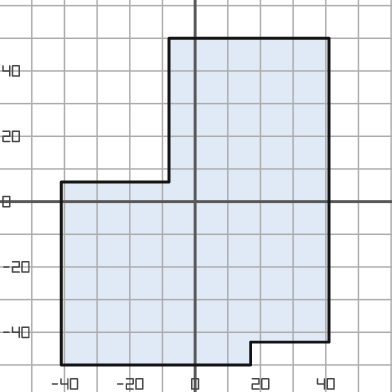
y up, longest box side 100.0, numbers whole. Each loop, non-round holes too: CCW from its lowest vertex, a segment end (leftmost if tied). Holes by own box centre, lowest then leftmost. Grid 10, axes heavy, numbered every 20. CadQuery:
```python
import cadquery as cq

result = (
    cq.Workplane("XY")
    .moveTo(-41.0, -50.0)
    .lineTo(17.0, -50.0)
    .lineTo(17.0, -43.0)
    .lineTo(41.0, -43.0)
    .lineTo(41.0, 50.0)
    .lineTo(-8.0, 50.0)
    .lineTo(-8.0, 6.0)
    .lineTo(-41.0, 6.0)
    .close()
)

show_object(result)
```